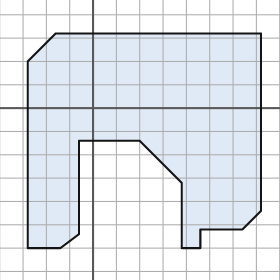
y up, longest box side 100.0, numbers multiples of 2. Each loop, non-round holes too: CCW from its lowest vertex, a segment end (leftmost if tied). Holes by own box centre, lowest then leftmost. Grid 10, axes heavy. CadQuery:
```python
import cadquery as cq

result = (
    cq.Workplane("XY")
    .moveTo(-28.0, -60.0)
    .lineTo(-14.0, -60.0)
    .lineTo(-6.0, -54.0)
    .lineTo(-6.0, -14.0)
    .lineTo(20.0, -14.0)
    .lineTo(38.0, -32.0)
    .lineTo(38.0, -60.0)
    .lineTo(46.0, -60.0)
    .lineTo(46.0, -52.0)
    .lineTo(64.0, -52.0)
    .lineTo(72.0, -44.0)
    .lineTo(72.0, 32.0)
    .lineTo(-16.0, 32.0)
    .lineTo(-28.0, 20.0)
    .close()
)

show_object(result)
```